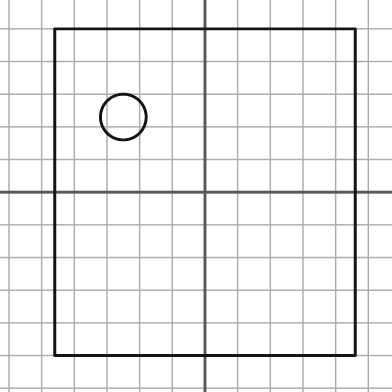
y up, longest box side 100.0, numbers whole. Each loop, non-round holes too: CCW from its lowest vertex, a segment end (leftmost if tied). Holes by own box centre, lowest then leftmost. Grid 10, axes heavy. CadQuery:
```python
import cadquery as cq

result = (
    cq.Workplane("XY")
    .moveTo(-46.0, -50.0)
    .lineTo(46.0, -50.0)
    .lineTo(46.0, 50.0)
    .lineTo(-46.0, 50.0)
    .close()
    .moveTo(-25.0, 23.0)
    .circle(7.0)
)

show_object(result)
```